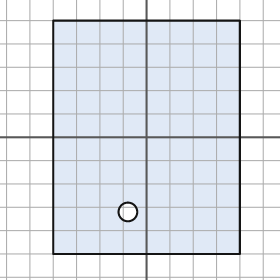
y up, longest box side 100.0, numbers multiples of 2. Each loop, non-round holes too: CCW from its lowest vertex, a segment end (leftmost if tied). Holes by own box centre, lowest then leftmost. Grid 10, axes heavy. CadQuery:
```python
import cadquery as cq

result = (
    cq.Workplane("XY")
    .moveTo(-40.0, -50.0)
    .lineTo(40.0, -50.0)
    .lineTo(40.0, 50.0)
    .lineTo(-40.0, 50.0)
    .close()
    .moveTo(-8.0, -32.0)
    .circle(4.0)
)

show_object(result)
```